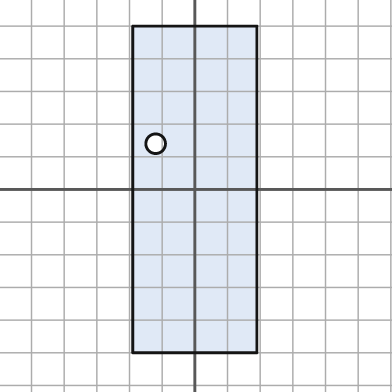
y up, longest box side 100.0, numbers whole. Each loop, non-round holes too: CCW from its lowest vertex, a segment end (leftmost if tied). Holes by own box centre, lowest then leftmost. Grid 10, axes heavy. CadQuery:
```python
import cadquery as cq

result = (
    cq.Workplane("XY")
    .moveTo(-19.0, -50.0)
    .lineTo(19.0, -50.0)
    .lineTo(19.0, 50.0)
    .lineTo(-19.0, 50.0)
    .close()
    .moveTo(-12.0, 14.0)
    .circle(3.0)
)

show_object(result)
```